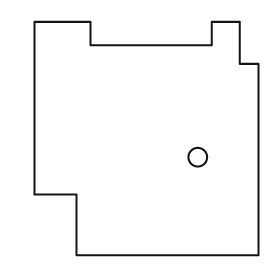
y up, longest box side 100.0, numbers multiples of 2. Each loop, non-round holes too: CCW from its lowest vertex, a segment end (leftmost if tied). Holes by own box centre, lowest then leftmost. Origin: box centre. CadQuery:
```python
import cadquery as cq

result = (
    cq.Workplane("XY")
    .moveTo(-30.0, -50.0)
    .lineTo(48.0, -50.0)
    .lineTo(48.0, 32.0)
    .lineTo(40.0, 32.0)
    .lineTo(40.0, 50.0)
    .lineTo(28.0, 50.0)
    .lineTo(28.0, 40.0)
    .lineTo(-24.0, 40.0)
    .lineTo(-24.0, 50.0)
    .lineTo(-48.0, 50.0)
    .lineTo(-48.0, -24.0)
    .lineTo(-30.0, -24.0)
    .close()
    .moveTo(22.0, -8.0)
    .circle(4.0)
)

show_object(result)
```